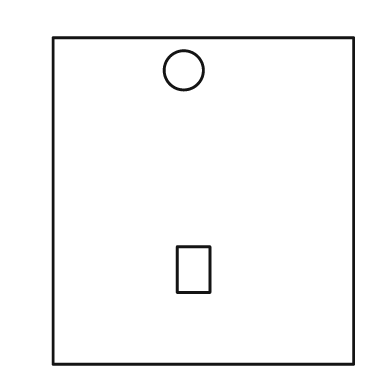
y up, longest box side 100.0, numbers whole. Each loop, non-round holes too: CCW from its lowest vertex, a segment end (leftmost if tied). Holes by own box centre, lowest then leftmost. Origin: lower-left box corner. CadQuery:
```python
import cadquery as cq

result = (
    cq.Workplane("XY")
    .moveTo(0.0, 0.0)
    .lineTo(92.0, 0.0)
    .lineTo(92.0, 100.0)
    .lineTo(0.0, 100.0)
    .close()
    .moveTo(38.0, 22.0)
    .lineTo(48.0, 22.0)
    .lineTo(48.0, 36.0)
    .lineTo(38.0, 36.0)
    .close()
    .moveTo(40.0, 90.0)
    .circle(6.0)
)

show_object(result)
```